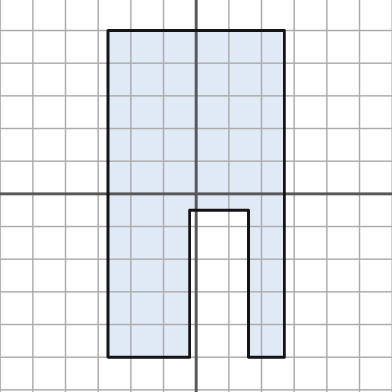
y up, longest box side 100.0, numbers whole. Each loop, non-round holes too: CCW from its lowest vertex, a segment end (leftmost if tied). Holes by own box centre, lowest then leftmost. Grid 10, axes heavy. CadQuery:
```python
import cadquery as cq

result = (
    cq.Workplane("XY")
    .moveTo(-27.0, -50.0)
    .lineTo(-2.0, -50.0)
    .lineTo(-2.0, -5.0)
    .lineTo(16.0, -5.0)
    .lineTo(16.0, -50.0)
    .lineTo(27.0, -50.0)
    .lineTo(27.0, 50.0)
    .lineTo(-27.0, 50.0)
    .close()
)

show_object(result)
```